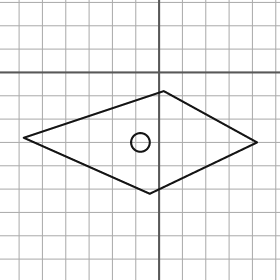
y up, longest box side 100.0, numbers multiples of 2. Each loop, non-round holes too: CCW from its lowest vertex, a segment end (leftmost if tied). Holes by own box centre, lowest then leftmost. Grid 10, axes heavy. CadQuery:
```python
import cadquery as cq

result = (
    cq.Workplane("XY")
    .moveTo(-4.0, -52.0)
    .lineTo(42.0, -30.0)
    .lineTo(2.0, -8.0)
    .lineTo(-58.0, -28.0)
    .close()
    .moveTo(-8.0, -30.0)
    .circle(4.0)
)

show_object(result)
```